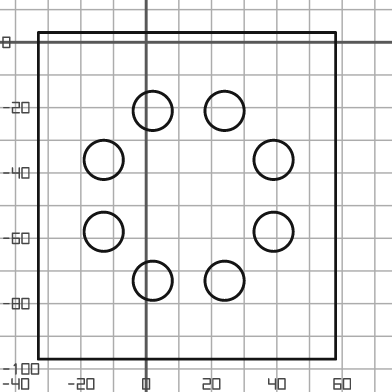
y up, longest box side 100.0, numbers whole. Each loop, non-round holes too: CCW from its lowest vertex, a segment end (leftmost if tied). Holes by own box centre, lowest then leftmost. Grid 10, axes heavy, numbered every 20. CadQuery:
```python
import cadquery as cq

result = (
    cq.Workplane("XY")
    .moveTo(-33.0, -97.0)
    .lineTo(58.0, -97.0)
    .lineTo(58.0, 3.0)
    .lineTo(-33.0, 3.0)
    .close()
    .moveTo(2.0, -73.0)
    .circle(6.0)
    .moveTo(24.0, -73.0)
    .circle(6.0)
    .moveTo(-13.0, -58.0)
    .circle(6.0)
    .moveTo(39.0, -58.0)
    .circle(6.0)
    .moveTo(-13.0, -36.0)
    .circle(6.0)
    .moveTo(39.0, -36.0)
    .circle(6.0)
    .moveTo(2.0, -21.0)
    .circle(6.0)
    .moveTo(24.0, -21.0)
    .circle(6.0)
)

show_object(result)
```